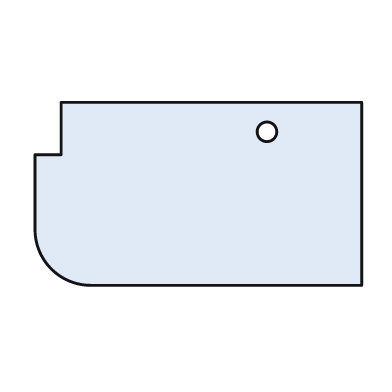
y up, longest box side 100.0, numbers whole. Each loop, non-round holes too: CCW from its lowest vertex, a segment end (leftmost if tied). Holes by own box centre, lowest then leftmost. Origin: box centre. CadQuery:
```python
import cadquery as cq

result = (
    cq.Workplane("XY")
    .moveTo(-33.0, -28.0)
    .lineTo(50.0, -28.0)
    .lineTo(50.0, 28.0)
    .lineTo(-42.0, 28.0)
    .lineTo(-42.0, 12.0)
    .lineTo(-50.0, 12.0)
    .lineTo(-50.0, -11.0)
    .threePointArc((-45.0, -23.0), (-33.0, -28.0))
    .close()
    .moveTo(21.0, 19.0)
    .circle(3.0)
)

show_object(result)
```